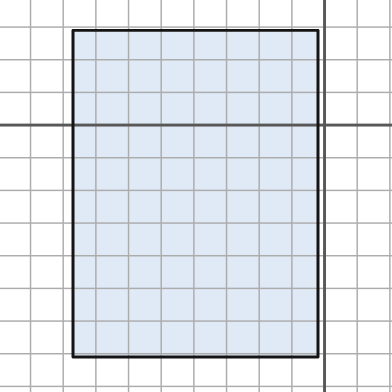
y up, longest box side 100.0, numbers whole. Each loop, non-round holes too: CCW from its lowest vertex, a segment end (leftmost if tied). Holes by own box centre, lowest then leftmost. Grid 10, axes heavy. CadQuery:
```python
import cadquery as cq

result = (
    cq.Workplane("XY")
    .moveTo(-77.0, -71.0)
    .lineTo(-2.0, -71.0)
    .lineTo(-2.0, 29.0)
    .lineTo(-77.0, 29.0)
    .close()
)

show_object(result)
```